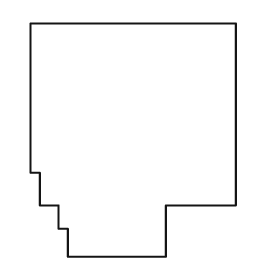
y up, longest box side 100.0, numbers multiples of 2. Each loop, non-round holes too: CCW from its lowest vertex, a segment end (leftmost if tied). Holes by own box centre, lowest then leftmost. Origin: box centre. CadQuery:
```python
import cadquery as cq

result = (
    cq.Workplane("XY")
    .moveTo(-28.0, -50.0)
    .lineTo(14.0, -50.0)
    .lineTo(14.0, -28.0)
    .lineTo(44.0, -28.0)
    .lineTo(44.0, 50.0)
    .lineTo(-44.0, 50.0)
    .lineTo(-44.0, -14.0)
    .lineTo(-40.0, -14.0)
    .lineTo(-40.0, -28.0)
    .lineTo(-32.0, -28.0)
    .lineTo(-32.0, -38.0)
    .lineTo(-28.0, -38.0)
    .close()
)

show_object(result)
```